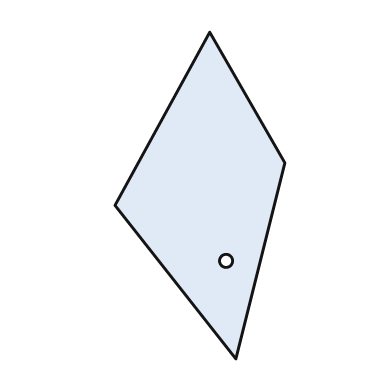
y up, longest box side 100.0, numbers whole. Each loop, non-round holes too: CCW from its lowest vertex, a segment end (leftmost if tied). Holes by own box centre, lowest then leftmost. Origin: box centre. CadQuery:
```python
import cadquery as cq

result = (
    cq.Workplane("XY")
    .moveTo(11.0, -50.0)
    .lineTo(26.0, 10.0)
    .lineTo(3.0, 50.0)
    .lineTo(-26.0, -3.0)
    .close()
    .moveTo(8.0, -20.0)
    .circle(2.0)
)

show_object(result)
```